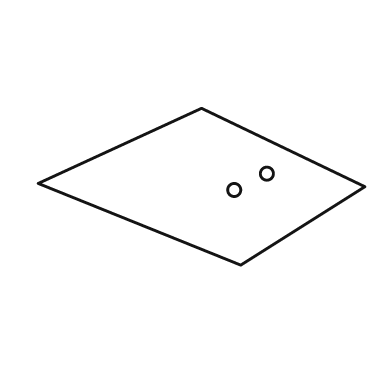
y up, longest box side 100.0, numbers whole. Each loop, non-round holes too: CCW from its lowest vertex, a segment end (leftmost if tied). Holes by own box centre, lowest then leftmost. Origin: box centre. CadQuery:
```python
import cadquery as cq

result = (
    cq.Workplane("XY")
    .moveTo(12.0, -24.0)
    .lineTo(50.0, 0.0)
    .lineTo(0.0, 24.0)
    .lineTo(-50.0, 1.0)
    .close()
    .moveTo(10.0, -1.0)
    .circle(2.0)
    .moveTo(20.0, 4.0)
    .circle(2.0)
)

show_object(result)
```